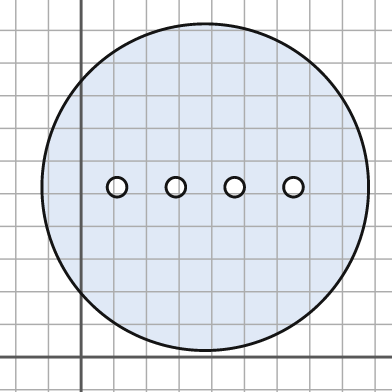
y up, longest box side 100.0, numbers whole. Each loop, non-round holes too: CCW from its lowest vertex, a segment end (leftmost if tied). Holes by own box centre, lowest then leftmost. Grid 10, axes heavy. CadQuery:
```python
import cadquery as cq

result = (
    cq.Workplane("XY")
    .moveTo(38.0, 52.0)
    .circle(50.0)
    .moveTo(11.0, 52.0)
    .circle(3.0)
    .moveTo(29.0, 52.0)
    .circle(3.0)
    .moveTo(47.0, 52.0)
    .circle(3.0)
    .moveTo(65.0, 52.0)
    .circle(3.0)
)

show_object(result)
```